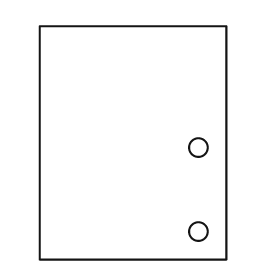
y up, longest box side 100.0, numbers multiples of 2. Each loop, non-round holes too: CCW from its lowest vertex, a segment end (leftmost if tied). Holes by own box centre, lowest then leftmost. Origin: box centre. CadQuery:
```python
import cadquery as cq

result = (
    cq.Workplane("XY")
    .moveTo(-40.0, -50.0)
    .lineTo(40.0, -50.0)
    .lineTo(40.0, 50.0)
    .lineTo(-40.0, 50.0)
    .close()
    .moveTo(28.0, -38.0)
    .circle(4.0)
    .moveTo(28.0, -2.0)
    .circle(4.0)
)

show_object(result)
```